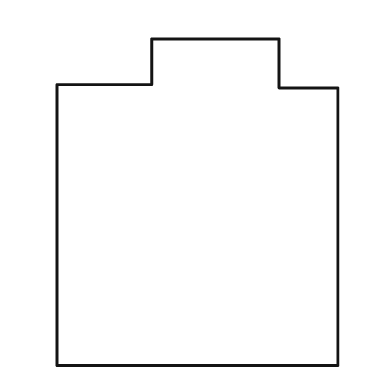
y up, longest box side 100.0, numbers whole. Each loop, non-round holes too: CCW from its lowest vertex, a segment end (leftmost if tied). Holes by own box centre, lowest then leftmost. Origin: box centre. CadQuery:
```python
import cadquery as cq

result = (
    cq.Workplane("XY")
    .moveTo(-43.0, -50.0)
    .lineTo(43.0, -50.0)
    .lineTo(43.0, 35.0)
    .lineTo(25.0, 35.0)
    .lineTo(25.0, 50.0)
    .lineTo(-14.0, 50.0)
    .lineTo(-14.0, 36.0)
    .lineTo(-43.0, 36.0)
    .close()
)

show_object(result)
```